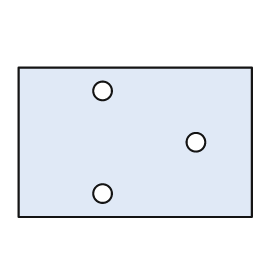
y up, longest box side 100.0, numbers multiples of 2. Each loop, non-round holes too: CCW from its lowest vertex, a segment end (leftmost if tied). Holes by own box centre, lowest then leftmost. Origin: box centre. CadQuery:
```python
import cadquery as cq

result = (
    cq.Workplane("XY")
    .moveTo(-50.0, -32.0)
    .lineTo(50.0, -32.0)
    .lineTo(50.0, 32.0)
    .lineTo(-50.0, 32.0)
    .close()
    .moveTo(-14.0, -22.0)
    .circle(4.0)
    .moveTo(26.0, 0.0)
    .circle(4.0)
    .moveTo(-14.0, 22.0)
    .circle(4.0)
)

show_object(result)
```